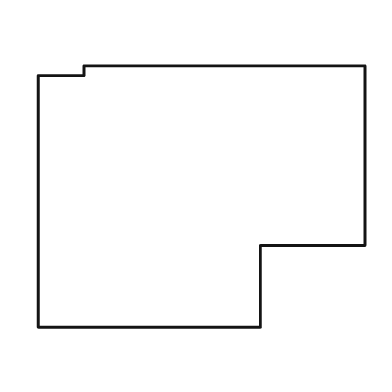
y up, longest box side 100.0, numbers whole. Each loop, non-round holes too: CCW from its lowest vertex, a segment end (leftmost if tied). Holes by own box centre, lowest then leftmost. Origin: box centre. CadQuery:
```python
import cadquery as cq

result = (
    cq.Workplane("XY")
    .moveTo(-50.0, -40.0)
    .lineTo(18.0, -40.0)
    .lineTo(18.0, -15.0)
    .lineTo(50.0, -15.0)
    .lineTo(50.0, 40.0)
    .lineTo(-36.0, 40.0)
    .lineTo(-36.0, 37.0)
    .lineTo(-50.0, 37.0)
    .close()
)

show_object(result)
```